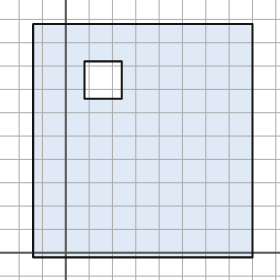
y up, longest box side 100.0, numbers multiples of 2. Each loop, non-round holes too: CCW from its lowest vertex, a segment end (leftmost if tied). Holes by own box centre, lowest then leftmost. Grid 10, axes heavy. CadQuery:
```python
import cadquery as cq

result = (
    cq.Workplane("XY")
    .moveTo(-14.0, -2.0)
    .lineTo(80.0, -2.0)
    .lineTo(80.0, 98.0)
    .lineTo(-14.0, 98.0)
    .close()
    .moveTo(8.0, 66.0)
    .lineTo(24.0, 66.0)
    .lineTo(24.0, 82.0)
    .lineTo(8.0, 82.0)
    .close()
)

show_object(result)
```